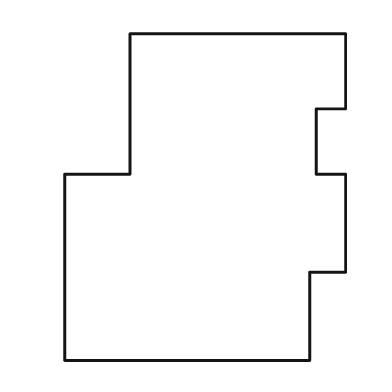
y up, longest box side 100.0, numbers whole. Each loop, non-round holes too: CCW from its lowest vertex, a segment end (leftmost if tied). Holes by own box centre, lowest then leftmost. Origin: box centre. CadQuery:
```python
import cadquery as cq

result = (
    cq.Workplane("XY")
    .moveTo(-43.0, -50.0)
    .lineTo(32.0, -50.0)
    .lineTo(32.0, -23.0)
    .lineTo(43.0, -23.0)
    .lineTo(43.0, 7.0)
    .lineTo(34.0, 7.0)
    .lineTo(34.0, 27.0)
    .lineTo(43.0, 27.0)
    .lineTo(43.0, 50.0)
    .lineTo(-23.0, 50.0)
    .lineTo(-23.0, 7.0)
    .lineTo(-43.0, 7.0)
    .close()
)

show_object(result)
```